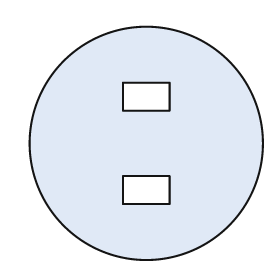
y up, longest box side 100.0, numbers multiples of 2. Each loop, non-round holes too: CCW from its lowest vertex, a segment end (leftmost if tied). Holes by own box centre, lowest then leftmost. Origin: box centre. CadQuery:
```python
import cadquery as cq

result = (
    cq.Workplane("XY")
    .moveTo(0.0, 0.0)
    .circle(50.0)
    .moveTo(-10.0, -26.0)
    .lineTo(10.0, -26.0)
    .lineTo(10.0, -14.0)
    .lineTo(-10.0, -14.0)
    .close()
    .moveTo(-10.0, 14.0)
    .lineTo(10.0, 14.0)
    .lineTo(10.0, 26.0)
    .lineTo(-10.0, 26.0)
    .close()
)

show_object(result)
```